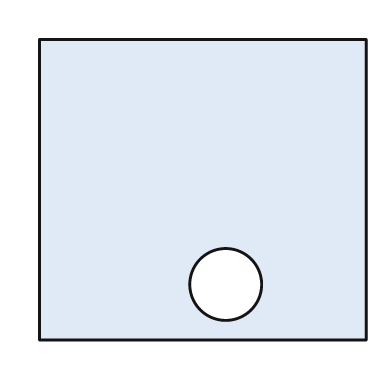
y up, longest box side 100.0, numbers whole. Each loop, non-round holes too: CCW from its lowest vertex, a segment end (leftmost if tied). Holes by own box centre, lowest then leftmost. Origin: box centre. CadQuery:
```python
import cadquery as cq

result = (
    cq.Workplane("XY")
    .moveTo(-50.0, -46.0)
    .lineTo(50.0, -46.0)
    .lineTo(50.0, 46.0)
    .lineTo(-50.0, 46.0)
    .close()
    .moveTo(7.0, -29.0)
    .circle(11.0)
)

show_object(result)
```